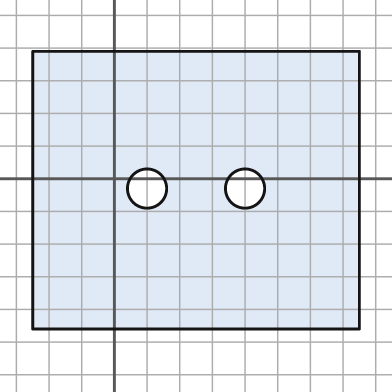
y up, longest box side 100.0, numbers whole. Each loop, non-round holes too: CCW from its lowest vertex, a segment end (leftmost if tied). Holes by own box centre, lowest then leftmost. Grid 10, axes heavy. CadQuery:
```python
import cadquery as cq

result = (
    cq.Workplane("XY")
    .moveTo(-25.0, -46.0)
    .lineTo(75.0, -46.0)
    .lineTo(75.0, 39.0)
    .lineTo(-25.0, 39.0)
    .close()
    .moveTo(10.0, -3.0)
    .circle(6.0)
    .moveTo(40.0, -3.0)
    .circle(6.0)
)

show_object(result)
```